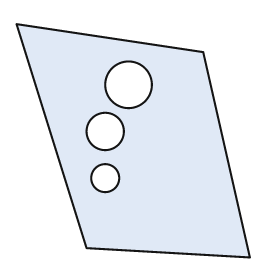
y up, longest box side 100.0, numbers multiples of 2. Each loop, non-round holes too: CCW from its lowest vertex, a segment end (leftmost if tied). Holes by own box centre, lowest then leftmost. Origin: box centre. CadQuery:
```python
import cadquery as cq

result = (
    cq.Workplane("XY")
    .moveTo(50.0, -50.0)
    .lineTo(30.0, 38.0)
    .lineTo(-50.0, 50.0)
    .lineTo(-20.0, -46.0)
    .close()
    .moveTo(-12.0, -16.0)
    .circle(6.0)
    .moveTo(-12.0, 4.0)
    .circle(8.0)
    .moveTo(-2.0, 24.0)
    .circle(10.0)
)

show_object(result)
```